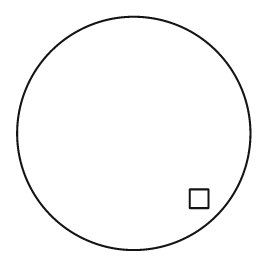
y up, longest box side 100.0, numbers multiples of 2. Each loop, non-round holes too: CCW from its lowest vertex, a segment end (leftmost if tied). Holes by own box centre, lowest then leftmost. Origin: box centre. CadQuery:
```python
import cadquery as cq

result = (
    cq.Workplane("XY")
    .moveTo(0.0, 0.0)
    .circle(50.0)
    .moveTo(24.0, -32.0)
    .lineTo(32.0, -32.0)
    .lineTo(32.0, -24.0)
    .lineTo(24.0, -24.0)
    .close()
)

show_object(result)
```